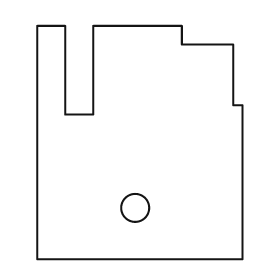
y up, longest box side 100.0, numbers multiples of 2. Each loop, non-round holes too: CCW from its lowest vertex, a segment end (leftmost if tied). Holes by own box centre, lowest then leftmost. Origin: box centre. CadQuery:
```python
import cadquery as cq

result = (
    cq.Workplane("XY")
    .moveTo(-44.0, -50.0)
    .lineTo(44.0, -50.0)
    .lineTo(44.0, 16.0)
    .lineTo(40.0, 16.0)
    .lineTo(40.0, 42.0)
    .lineTo(18.0, 42.0)
    .lineTo(18.0, 50.0)
    .lineTo(-20.0, 50.0)
    .lineTo(-20.0, 12.0)
    .lineTo(-32.0, 12.0)
    .lineTo(-32.0, 50.0)
    .lineTo(-44.0, 50.0)
    .close()
    .moveTo(-2.0, -28.0)
    .circle(6.0)
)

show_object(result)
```